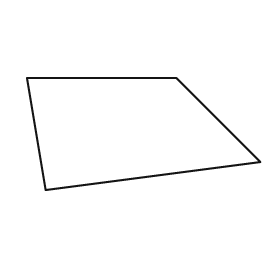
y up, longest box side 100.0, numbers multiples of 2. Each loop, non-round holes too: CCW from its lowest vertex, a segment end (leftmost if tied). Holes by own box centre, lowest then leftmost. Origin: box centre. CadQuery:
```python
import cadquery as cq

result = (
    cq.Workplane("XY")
    .moveTo(-42.0, -24.0)
    .lineTo(50.0, -12.0)
    .lineTo(14.0, 24.0)
    .lineTo(-50.0, 24.0)
    .close()
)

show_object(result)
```